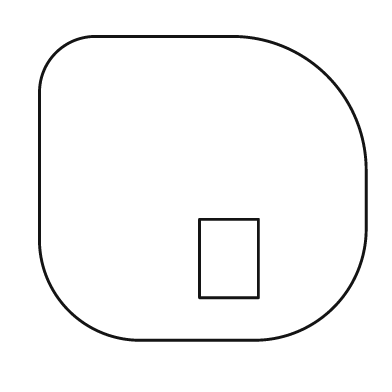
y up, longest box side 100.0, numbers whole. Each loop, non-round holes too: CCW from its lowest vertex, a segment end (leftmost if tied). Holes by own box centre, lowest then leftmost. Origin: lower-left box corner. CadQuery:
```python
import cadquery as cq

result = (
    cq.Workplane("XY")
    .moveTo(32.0, 0.0)
    .lineTo(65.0, 0.0)
    .threePointArc((90.0, 10.0), (100.0, 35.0))
    .lineTo(100.0, 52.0)
    .threePointArc((88.0, 81.0), (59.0, 93.0))
    .lineTo(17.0, 93.0)
    .threePointArc((5.0, 88.0), (0.0, 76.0))
    .lineTo(0.0, 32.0)
    .threePointArc((9.0, 9.0), (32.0, 0.0))
    .close()
    .moveTo(49.0, 13.0)
    .lineTo(67.0, 13.0)
    .lineTo(67.0, 37.0)
    .lineTo(49.0, 37.0)
    .close()
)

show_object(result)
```